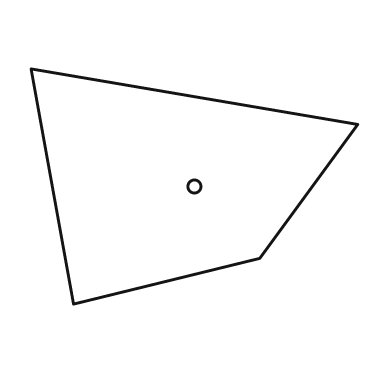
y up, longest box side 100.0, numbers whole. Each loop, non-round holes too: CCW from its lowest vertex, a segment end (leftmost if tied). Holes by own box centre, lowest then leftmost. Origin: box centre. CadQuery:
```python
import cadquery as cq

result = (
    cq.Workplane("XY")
    .moveTo(-37.0, -36.0)
    .lineTo(20.0, -22.0)
    .lineTo(50.0, 19.0)
    .lineTo(-50.0, 36.0)
    .close()
    .moveTo(0.0, 0.0)
    .circle(2.0)
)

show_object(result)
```